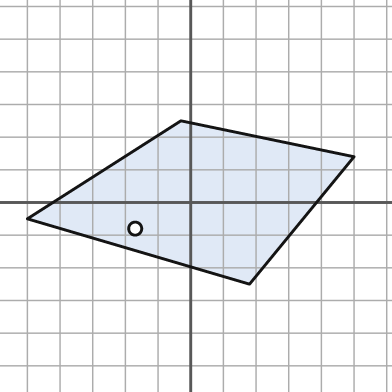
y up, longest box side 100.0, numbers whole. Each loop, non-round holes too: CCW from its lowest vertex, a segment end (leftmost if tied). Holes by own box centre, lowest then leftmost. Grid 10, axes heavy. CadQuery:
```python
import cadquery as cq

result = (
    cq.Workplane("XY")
    .moveTo(18.0, -25.0)
    .lineTo(50.0, 14.0)
    .lineTo(-3.0, 25.0)
    .lineTo(-50.0, -5.0)
    .close()
    .moveTo(-17.0, -8.0)
    .circle(2.0)
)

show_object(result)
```